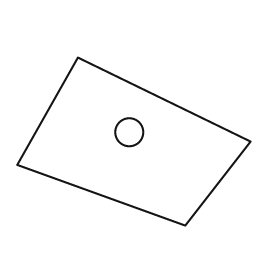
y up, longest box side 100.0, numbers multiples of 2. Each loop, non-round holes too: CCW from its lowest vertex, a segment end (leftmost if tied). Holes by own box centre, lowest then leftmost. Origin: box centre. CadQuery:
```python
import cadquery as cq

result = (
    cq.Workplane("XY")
    .moveTo(22.0, -36.0)
    .lineTo(50.0, 0.0)
    .lineTo(-24.0, 36.0)
    .lineTo(-50.0, -10.0)
    .close()
    .moveTo(-2.0, 4.0)
    .circle(6.0)
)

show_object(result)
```